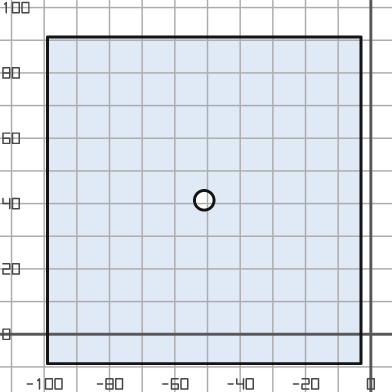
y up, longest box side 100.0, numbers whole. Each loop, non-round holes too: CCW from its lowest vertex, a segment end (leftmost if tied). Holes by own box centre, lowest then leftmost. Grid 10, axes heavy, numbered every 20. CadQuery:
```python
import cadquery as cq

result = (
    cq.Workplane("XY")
    .moveTo(-99.0, -9.0)
    .lineTo(-3.0, -9.0)
    .lineTo(-3.0, 91.0)
    .lineTo(-99.0, 91.0)
    .close()
    .moveTo(-51.0, 41.0)
    .circle(3.0)
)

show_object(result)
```